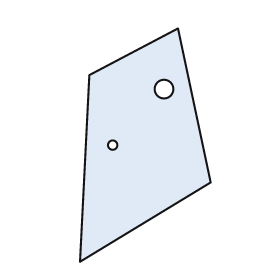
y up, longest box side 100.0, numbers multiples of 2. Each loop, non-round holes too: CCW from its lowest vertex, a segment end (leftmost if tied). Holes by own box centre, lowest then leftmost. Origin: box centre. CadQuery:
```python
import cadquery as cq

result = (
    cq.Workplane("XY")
    .moveTo(-28.0, -50.0)
    .lineTo(28.0, -16.0)
    .lineTo(14.0, 50.0)
    .lineTo(-24.0, 30.0)
    .close()
    .moveTo(-14.0, 0.0)
    .circle(2.0)
    .moveTo(8.0, 24.0)
    .circle(4.0)
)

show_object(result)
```